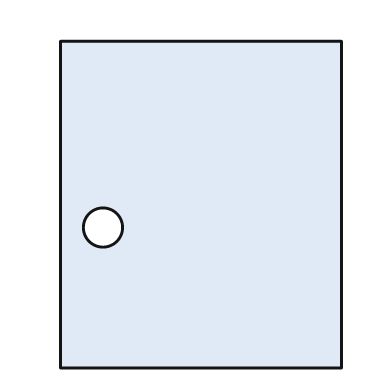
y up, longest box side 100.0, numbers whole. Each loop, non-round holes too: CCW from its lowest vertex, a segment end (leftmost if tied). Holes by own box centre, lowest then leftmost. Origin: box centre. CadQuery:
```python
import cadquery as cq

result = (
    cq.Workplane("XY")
    .moveTo(-43.0, -50.0)
    .lineTo(43.0, -50.0)
    .lineTo(43.0, 50.0)
    .lineTo(-43.0, 50.0)
    .close()
    .moveTo(-30.0, -7.0)
    .circle(6.0)
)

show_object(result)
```